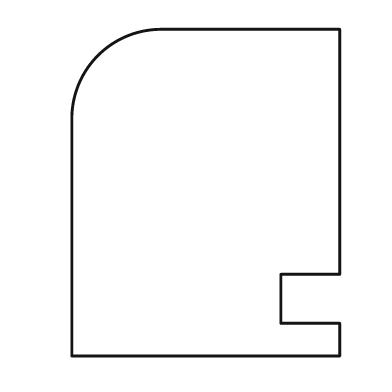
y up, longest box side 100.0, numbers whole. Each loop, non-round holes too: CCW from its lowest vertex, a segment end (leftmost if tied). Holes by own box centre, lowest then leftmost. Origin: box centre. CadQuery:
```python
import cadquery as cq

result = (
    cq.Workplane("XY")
    .moveTo(-41.0, -50.0)
    .lineTo(41.0, -50.0)
    .lineTo(41.0, -40.0)
    .lineTo(23.0, -40.0)
    .lineTo(23.0, -25.0)
    .lineTo(41.0, -25.0)
    .lineTo(41.0, 50.0)
    .lineTo(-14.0, 50.0)
    .threePointArc((-33.0, 42.0), (-41.0, 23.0))
    .close()
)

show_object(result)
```